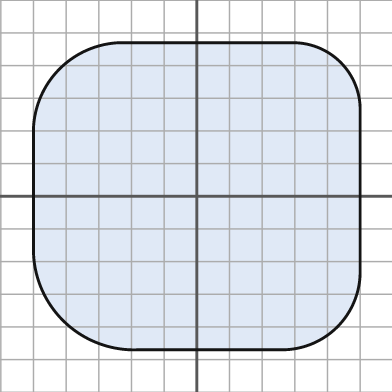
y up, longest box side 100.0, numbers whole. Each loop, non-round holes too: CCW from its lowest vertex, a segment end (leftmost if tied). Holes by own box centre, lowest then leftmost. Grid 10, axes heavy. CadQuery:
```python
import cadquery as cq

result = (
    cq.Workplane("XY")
    .moveTo(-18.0, -47.0)
    .lineTo(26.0, -47.0)
    .threePointArc((43.0, -40.0), (50.0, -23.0))
    .lineTo(50.0, 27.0)
    .threePointArc((44.0, 41.0), (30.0, 47.0))
    .lineTo(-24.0, 47.0)
    .threePointArc((-42.0, 39.0), (-50.0, 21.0))
    .lineTo(-50.0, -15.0)
    .threePointArc((-41.0, -38.0), (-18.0, -47.0))
    .close()
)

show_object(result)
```